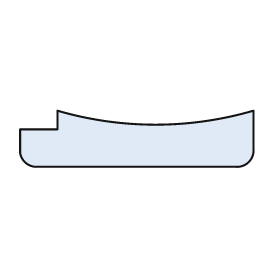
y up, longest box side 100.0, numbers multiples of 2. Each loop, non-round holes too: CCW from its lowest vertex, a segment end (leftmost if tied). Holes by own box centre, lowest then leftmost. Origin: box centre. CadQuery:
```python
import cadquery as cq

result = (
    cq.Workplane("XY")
    .moveTo(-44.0, -12.0)
    .lineTo(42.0, -12.0)
    .threePointArc((48.0, -10.0), (50.0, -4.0))
    .lineTo(50.0, 12.0)
    .threePointArc((8.0, 6.0), (-34.0, 12.0))
    .lineTo(-34.0, 4.0)
    .lineTo(-50.0, 4.0)
    .lineTo(-50.0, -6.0)
    .threePointArc((-48.0, -10.0), (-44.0, -12.0))
    .close()
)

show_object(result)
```